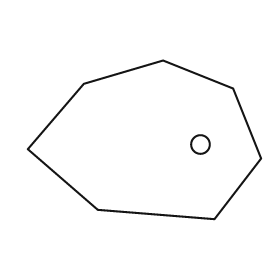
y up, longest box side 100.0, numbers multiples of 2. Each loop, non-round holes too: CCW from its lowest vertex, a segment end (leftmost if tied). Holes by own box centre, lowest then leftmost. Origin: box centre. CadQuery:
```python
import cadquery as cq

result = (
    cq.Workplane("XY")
    .moveTo(30.0, -34.0)
    .lineTo(50.0, -8.0)
    .lineTo(38.0, 22.0)
    .lineTo(8.0, 34.0)
    .lineTo(-26.0, 24.0)
    .lineTo(-50.0, -4.0)
    .lineTo(-20.0, -30.0)
    .close()
    .moveTo(24.0, -2.0)
    .circle(4.0)
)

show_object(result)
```